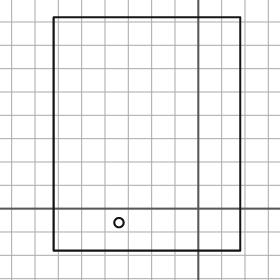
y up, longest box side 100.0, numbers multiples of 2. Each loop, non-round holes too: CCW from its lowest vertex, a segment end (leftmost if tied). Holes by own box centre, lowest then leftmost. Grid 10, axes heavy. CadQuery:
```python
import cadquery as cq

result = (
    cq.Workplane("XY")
    .moveTo(-62.0, -18.0)
    .lineTo(18.0, -18.0)
    .lineTo(18.0, 82.0)
    .lineTo(-62.0, 82.0)
    .close()
    .moveTo(-34.0, -6.0)
    .circle(2.0)
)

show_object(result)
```